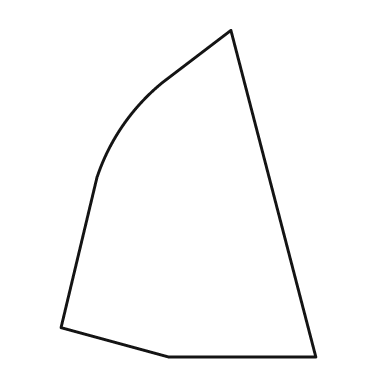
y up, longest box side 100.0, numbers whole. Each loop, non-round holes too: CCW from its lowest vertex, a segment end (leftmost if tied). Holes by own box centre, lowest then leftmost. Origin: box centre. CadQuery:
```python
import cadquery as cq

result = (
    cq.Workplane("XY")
    .moveTo(-6.0, -50.0)
    .lineTo(39.0, -50.0)
    .lineTo(13.0, 50.0)
    .lineTo(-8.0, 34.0)
    .threePointArc((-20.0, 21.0), (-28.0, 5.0))
    .lineTo(-39.0, -41.0)
    .close()
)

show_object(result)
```